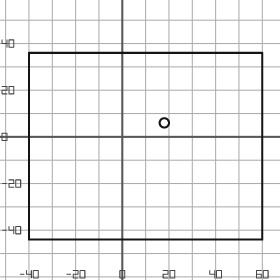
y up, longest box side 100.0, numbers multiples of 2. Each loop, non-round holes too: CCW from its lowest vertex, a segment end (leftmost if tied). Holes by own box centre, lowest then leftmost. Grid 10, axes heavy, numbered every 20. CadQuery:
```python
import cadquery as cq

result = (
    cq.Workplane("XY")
    .moveTo(-40.0, -44.0)
    .lineTo(60.0, -44.0)
    .lineTo(60.0, 36.0)
    .lineTo(-40.0, 36.0)
    .close()
    .moveTo(18.0, 6.0)
    .circle(2.0)
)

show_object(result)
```